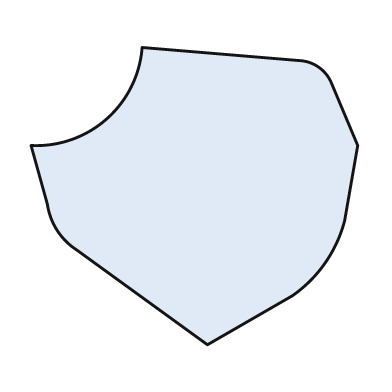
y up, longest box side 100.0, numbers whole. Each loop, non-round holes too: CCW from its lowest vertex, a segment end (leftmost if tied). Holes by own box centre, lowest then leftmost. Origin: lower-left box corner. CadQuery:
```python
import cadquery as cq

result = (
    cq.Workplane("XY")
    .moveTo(54.0, 0.0)
    .lineTo(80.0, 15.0)
    .threePointArc((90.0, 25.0), (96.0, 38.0))
    .lineTo(100.0, 61.0)
    .lineTo(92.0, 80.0)
    .threePointArc((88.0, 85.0), (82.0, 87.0))
    .lineTo(34.0, 91.0)
    .threePointArc((23.0, 69.0), (0.0, 61.0))
    .lineTo(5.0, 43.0)
    .threePointArc((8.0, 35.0), (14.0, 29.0))
    .close()
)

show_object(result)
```